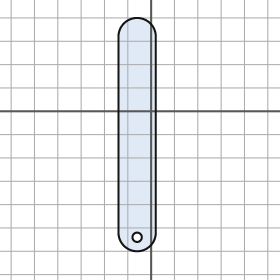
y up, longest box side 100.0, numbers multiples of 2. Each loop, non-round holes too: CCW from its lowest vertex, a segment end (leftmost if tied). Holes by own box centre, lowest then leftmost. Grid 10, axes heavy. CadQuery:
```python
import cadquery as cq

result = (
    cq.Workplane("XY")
    .moveTo(-14.0, -52.0)
    .threePointArc((-6.0, -60.0), (2.0, -52.0))
    .lineTo(2.0, 32.0)
    .threePointArc((-6.0, 40.0), (-14.0, 32.0))
    .close()
    .moveTo(-6.0, -54.0)
    .circle(2.0)
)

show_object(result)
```